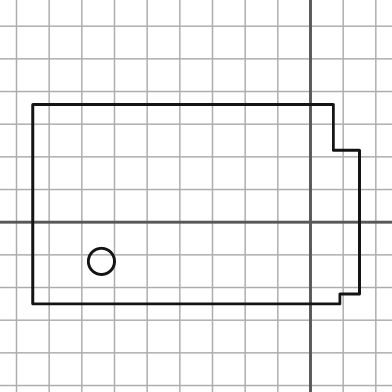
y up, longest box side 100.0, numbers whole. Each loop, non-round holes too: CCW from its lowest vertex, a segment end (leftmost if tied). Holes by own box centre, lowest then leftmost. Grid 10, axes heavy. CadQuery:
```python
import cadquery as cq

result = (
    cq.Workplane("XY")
    .moveTo(-85.0, -25.0)
    .lineTo(9.0, -25.0)
    .lineTo(9.0, -22.0)
    .lineTo(15.0, -22.0)
    .lineTo(15.0, 22.0)
    .lineTo(7.0, 22.0)
    .lineTo(7.0, 36.0)
    .lineTo(-85.0, 36.0)
    .close()
    .moveTo(-64.0, -12.0)
    .circle(4.0)
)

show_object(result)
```